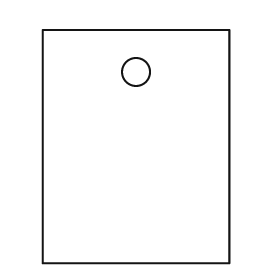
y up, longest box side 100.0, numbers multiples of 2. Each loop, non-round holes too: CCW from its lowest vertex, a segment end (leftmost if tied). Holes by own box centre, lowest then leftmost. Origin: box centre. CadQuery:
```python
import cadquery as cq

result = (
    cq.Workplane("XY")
    .moveTo(-40.0, -50.0)
    .lineTo(40.0, -50.0)
    .lineTo(40.0, 50.0)
    .lineTo(-40.0, 50.0)
    .close()
    .moveTo(0.0, 32.0)
    .circle(6.0)
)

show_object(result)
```